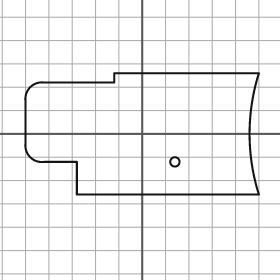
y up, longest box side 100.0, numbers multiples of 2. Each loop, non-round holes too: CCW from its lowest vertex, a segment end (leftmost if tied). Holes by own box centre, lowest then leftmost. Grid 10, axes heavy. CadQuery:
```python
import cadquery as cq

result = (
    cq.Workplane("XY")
    .moveTo(-28.0, -26.0)
    .lineTo(50.0, -26.0)
    .threePointArc((46.0, 0.0), (50.0, 26.0))
    .lineTo(-12.0, 26.0)
    .lineTo(-12.0, 22.0)
    .lineTo(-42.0, 22.0)
    .threePointArc((-48.0, 20.0), (-50.0, 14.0))
    .lineTo(-50.0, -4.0)
    .threePointArc((-48.0, -10.0), (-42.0, -12.0))
    .lineTo(-28.0, -12.0)
    .close()
    .moveTo(14.0, -12.0)
    .circle(2.0)
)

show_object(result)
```